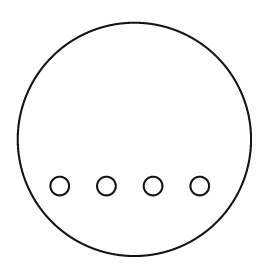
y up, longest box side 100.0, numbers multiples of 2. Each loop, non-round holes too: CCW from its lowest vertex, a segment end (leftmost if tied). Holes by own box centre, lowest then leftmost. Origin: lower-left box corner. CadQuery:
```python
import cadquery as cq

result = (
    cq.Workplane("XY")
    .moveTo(50.0, 50.0)
    .circle(50.0)
    .moveTo(18.0, 30.0)
    .circle(4.0)
    .moveTo(38.0, 30.0)
    .circle(4.0)
    .moveTo(58.0, 30.0)
    .circle(4.0)
    .moveTo(78.0, 30.0)
    .circle(4.0)
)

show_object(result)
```